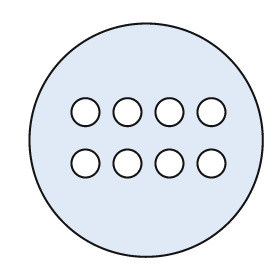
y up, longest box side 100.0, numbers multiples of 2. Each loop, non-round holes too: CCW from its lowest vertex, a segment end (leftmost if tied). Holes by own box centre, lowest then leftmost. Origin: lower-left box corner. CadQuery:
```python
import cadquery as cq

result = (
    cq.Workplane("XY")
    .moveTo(50.0, 50.0)
    .circle(50.0)
    .moveTo(24.0, 40.0)
    .circle(6.0)
    .moveTo(42.0, 40.0)
    .circle(6.0)
    .moveTo(60.0, 40.0)
    .circle(6.0)
    .moveTo(78.0, 40.0)
    .circle(6.0)
    .moveTo(24.0, 62.0)
    .circle(6.0)
    .moveTo(42.0, 62.0)
    .circle(6.0)
    .moveTo(60.0, 62.0)
    .circle(6.0)
    .moveTo(78.0, 62.0)
    .circle(6.0)
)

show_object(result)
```